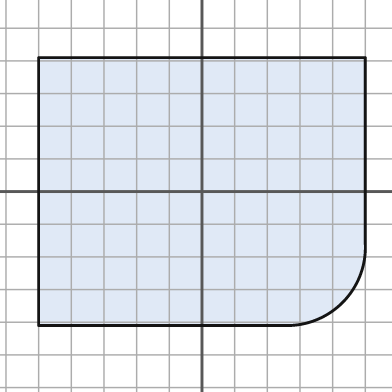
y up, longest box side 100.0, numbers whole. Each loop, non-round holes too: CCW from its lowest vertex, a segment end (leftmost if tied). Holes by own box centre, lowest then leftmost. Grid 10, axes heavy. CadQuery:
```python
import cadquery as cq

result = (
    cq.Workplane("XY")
    .moveTo(-50.0, -41.0)
    .lineTo(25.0, -41.0)
    .threePointArc((43.0, -34.0), (50.0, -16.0))
    .lineTo(50.0, 41.0)
    .lineTo(-50.0, 41.0)
    .close()
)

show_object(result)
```